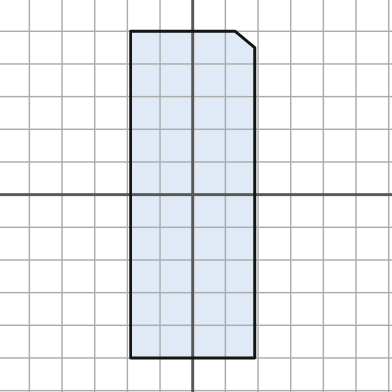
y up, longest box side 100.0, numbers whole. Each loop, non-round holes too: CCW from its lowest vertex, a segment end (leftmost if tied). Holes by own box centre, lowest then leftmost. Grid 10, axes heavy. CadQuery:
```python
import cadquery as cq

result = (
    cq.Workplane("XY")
    .moveTo(-19.0, -50.0)
    .lineTo(19.0, -50.0)
    .lineTo(19.0, 45.0)
    .lineTo(13.0, 50.0)
    .lineTo(-19.0, 50.0)
    .close()
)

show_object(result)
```